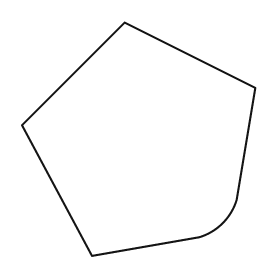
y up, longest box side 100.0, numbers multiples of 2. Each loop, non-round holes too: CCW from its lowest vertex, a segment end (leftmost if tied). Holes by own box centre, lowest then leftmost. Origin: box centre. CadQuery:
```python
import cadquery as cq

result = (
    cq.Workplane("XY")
    .moveTo(-20.0, -50.0)
    .lineTo(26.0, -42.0)
    .threePointArc((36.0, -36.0), (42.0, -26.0))
    .lineTo(50.0, 22.0)
    .lineTo(-6.0, 50.0)
    .lineTo(-50.0, 6.0)
    .close()
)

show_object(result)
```